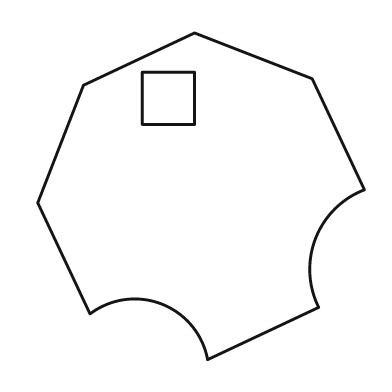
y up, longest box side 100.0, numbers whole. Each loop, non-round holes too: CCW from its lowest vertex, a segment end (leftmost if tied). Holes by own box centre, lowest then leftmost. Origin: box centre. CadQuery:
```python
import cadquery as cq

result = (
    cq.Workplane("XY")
    .moveTo(2.0, -50.0)
    .lineTo(36.0, -34.0)
    .threePointArc((35.0, -13.0), (50.0, 2.0))
    .lineTo(34.0, 36.0)
    .lineTo(-2.0, 50.0)
    .lineTo(-36.0, 34.0)
    .lineTo(-50.0, -2.0)
    .lineTo(-34.0, -36.0)
    .threePointArc((-12.0, -33.0), (2.0, -50.0))
    .close()
    .moveTo(-18.0, 22.0)
    .lineTo(-2.0, 22.0)
    .lineTo(-2.0, 38.0)
    .lineTo(-18.0, 38.0)
    .close()
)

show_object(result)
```